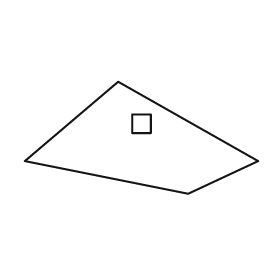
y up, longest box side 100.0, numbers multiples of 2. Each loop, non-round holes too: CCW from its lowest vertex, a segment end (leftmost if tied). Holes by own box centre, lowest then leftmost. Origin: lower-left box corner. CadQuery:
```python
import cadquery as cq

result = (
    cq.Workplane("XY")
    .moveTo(70.0, 0.0)
    .lineTo(100.0, 14.0)
    .lineTo(40.0, 48.0)
    .lineTo(0.0, 14.0)
    .close()
    .moveTo(46.0, 26.0)
    .lineTo(54.0, 26.0)
    .lineTo(54.0, 34.0)
    .lineTo(46.0, 34.0)
    .close()
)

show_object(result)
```